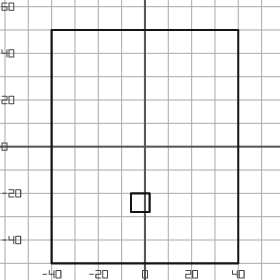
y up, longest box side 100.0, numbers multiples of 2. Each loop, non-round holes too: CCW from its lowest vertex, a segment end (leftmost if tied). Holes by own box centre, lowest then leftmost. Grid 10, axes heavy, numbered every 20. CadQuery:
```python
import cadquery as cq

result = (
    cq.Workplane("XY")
    .moveTo(-40.0, -50.0)
    .lineTo(40.0, -50.0)
    .lineTo(40.0, 50.0)
    .lineTo(-40.0, 50.0)
    .close()
    .moveTo(-6.0, -28.0)
    .lineTo(2.0, -28.0)
    .lineTo(2.0, -20.0)
    .lineTo(-6.0, -20.0)
    .close()
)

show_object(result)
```